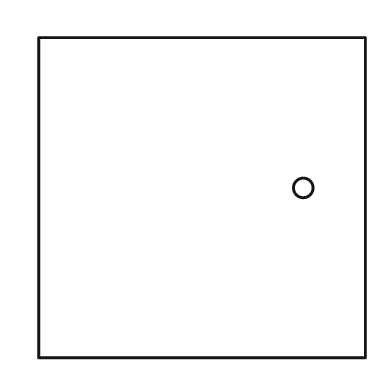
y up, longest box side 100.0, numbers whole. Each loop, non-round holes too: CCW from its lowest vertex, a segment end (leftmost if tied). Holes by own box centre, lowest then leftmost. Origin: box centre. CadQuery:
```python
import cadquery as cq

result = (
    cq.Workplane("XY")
    .moveTo(-50.0, -49.0)
    .lineTo(50.0, -49.0)
    .lineTo(50.0, 49.0)
    .lineTo(-50.0, 49.0)
    .close()
    .moveTo(31.0, 3.0)
    .circle(3.0)
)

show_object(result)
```